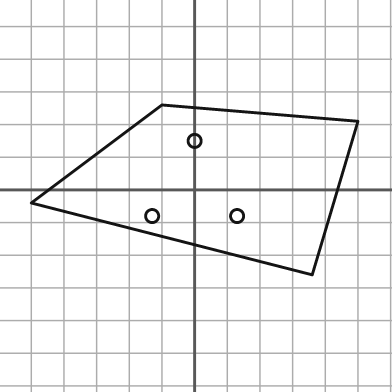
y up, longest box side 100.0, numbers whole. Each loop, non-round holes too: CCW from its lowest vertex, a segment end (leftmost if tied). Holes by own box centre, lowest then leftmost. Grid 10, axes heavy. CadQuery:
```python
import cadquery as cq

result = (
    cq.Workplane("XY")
    .moveTo(36.0, -26.0)
    .lineTo(50.0, 21.0)
    .lineTo(-10.0, 26.0)
    .lineTo(-50.0, -4.0)
    .close()
    .moveTo(-13.0, -8.0)
    .circle(2.0)
    .moveTo(13.0, -8.0)
    .circle(2.0)
    .moveTo(0.0, 15.0)
    .circle(2.0)
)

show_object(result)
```